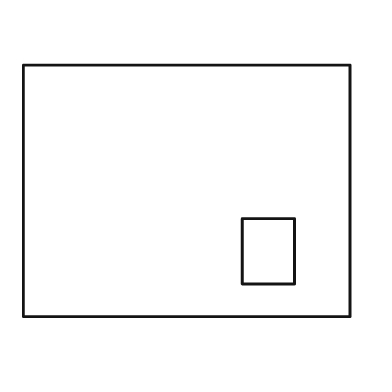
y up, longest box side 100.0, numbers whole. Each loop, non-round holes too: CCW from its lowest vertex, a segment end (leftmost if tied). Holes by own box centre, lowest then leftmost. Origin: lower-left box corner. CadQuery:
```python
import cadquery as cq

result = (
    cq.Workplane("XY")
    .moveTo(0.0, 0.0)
    .lineTo(100.0, 0.0)
    .lineTo(100.0, 77.0)
    .lineTo(0.0, 77.0)
    .close()
    .moveTo(67.0, 10.0)
    .lineTo(83.0, 10.0)
    .lineTo(83.0, 30.0)
    .lineTo(67.0, 30.0)
    .close()
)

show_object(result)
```